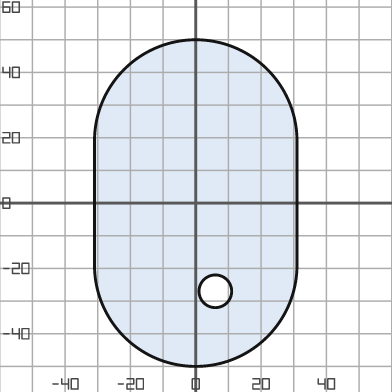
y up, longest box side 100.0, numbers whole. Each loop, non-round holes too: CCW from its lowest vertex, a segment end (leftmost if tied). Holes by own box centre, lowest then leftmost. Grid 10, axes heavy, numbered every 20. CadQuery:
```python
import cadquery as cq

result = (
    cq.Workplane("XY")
    .moveTo(-31.0, -19.0)
    .threePointArc((0.0, -50.0), (31.0, -19.0))
    .lineTo(31.0, 19.0)
    .threePointArc((0.0, 50.0), (-31.0, 19.0))
    .close()
    .moveTo(6.0, -27.0)
    .circle(5.0)
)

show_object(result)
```